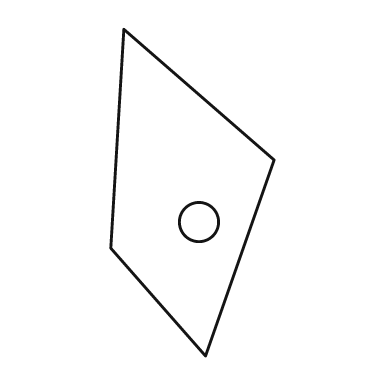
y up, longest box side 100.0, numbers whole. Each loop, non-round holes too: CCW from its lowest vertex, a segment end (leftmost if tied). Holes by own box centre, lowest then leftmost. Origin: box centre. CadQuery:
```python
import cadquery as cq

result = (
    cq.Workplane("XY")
    .moveTo(4.0, -50.0)
    .lineTo(25.0, 10.0)
    .lineTo(-21.0, 50.0)
    .lineTo(-25.0, -17.0)
    .close()
    .moveTo(2.0, -9.0)
    .circle(6.0)
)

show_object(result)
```